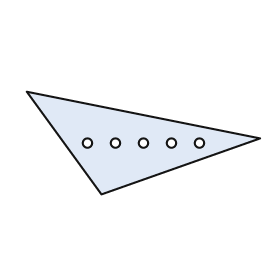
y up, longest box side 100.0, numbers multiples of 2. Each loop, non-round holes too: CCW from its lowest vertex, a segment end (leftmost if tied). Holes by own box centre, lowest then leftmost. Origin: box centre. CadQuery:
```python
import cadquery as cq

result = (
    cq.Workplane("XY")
    .moveTo(-18.0, -22.0)
    .lineTo(50.0, 2.0)
    .lineTo(-50.0, 22.0)
    .close()
    .moveTo(-24.0, 0.0)
    .circle(2.0)
    .moveTo(-12.0, 0.0)
    .circle(2.0)
    .moveTo(0.0, 0.0)
    .circle(2.0)
    .moveTo(12.0, 0.0)
    .circle(2.0)
    .moveTo(24.0, 0.0)
    .circle(2.0)
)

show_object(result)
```